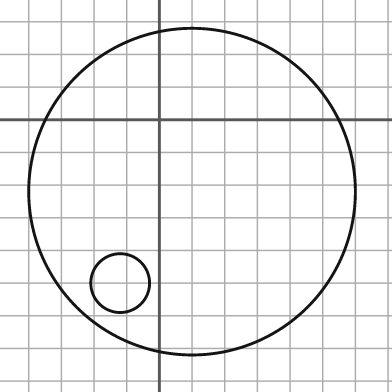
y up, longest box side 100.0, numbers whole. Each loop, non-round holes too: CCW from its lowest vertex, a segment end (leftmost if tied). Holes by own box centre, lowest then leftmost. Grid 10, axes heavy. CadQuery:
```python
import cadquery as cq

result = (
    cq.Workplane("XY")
    .moveTo(10.0, -22.0)
    .circle(50.0)
    .moveTo(-12.0, -50.0)
    .circle(9.0)
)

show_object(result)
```